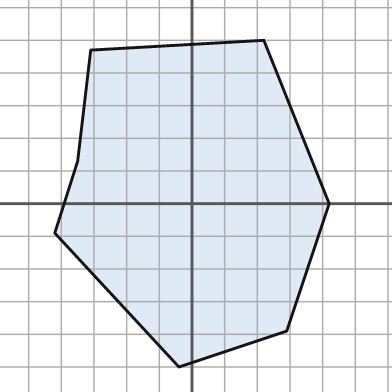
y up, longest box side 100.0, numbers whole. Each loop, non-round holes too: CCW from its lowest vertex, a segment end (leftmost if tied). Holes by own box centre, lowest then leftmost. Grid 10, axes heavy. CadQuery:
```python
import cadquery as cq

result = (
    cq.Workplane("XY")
    .moveTo(-4.0, -50.0)
    .lineTo(29.0, -39.0)
    .lineTo(42.0, 0.0)
    .lineTo(22.0, 50.0)
    .lineTo(-31.0, 47.0)
    .lineTo(-35.0, 13.0)
    .lineTo(-42.0, -9.0)
    .close()
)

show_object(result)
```